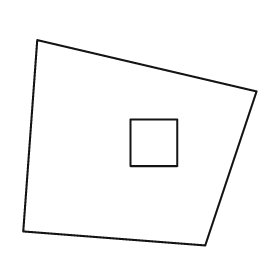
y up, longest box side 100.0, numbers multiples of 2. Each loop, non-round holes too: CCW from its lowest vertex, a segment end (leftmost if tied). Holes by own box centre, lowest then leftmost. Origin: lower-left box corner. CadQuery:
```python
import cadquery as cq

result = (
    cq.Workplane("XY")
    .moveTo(78.0, 0.0)
    .lineTo(100.0, 66.0)
    .lineTo(6.0, 88.0)
    .lineTo(0.0, 6.0)
    .close()
    .moveTo(46.0, 34.0)
    .lineTo(66.0, 34.0)
    .lineTo(66.0, 54.0)
    .lineTo(46.0, 54.0)
    .close()
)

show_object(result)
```